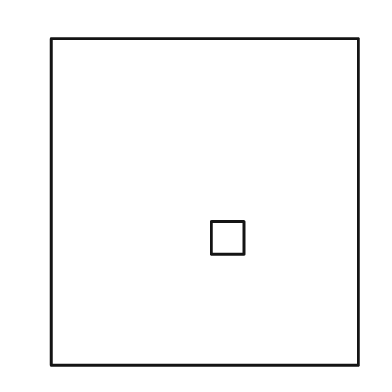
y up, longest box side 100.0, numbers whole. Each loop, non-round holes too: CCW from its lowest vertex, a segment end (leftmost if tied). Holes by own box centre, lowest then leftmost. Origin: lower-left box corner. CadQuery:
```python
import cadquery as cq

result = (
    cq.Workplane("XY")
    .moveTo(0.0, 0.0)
    .lineTo(94.0, 0.0)
    .lineTo(94.0, 100.0)
    .lineTo(0.0, 100.0)
    .close()
    .moveTo(49.0, 34.0)
    .lineTo(59.0, 34.0)
    .lineTo(59.0, 44.0)
    .lineTo(49.0, 44.0)
    .close()
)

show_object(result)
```